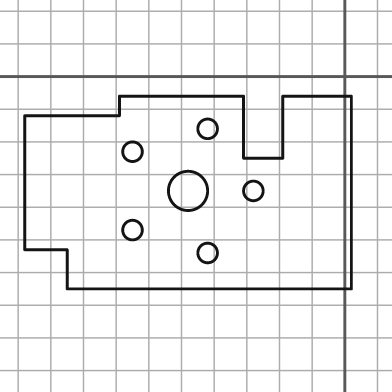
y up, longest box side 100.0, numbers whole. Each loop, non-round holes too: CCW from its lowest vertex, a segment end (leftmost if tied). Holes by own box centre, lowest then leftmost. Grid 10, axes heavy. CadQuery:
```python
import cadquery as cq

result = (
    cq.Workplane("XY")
    .moveTo(-85.0, -65.0)
    .lineTo(2.0, -65.0)
    .lineTo(2.0, -6.0)
    .lineTo(-19.0, -6.0)
    .lineTo(-19.0, -25.0)
    .lineTo(-31.0, -25.0)
    .lineTo(-31.0, -6.0)
    .lineTo(-69.0, -6.0)
    .lineTo(-69.0, -12.0)
    .lineTo(-98.0, -12.0)
    .lineTo(-98.0, -53.0)
    .lineTo(-85.0, -53.0)
    .close()
    .moveTo(-42.0, -54.0)
    .circle(3.0)
    .moveTo(-65.0, -47.0)
    .circle(3.0)
    .moveTo(-48.0, -35.0)
    .circle(6.0)
    .moveTo(-28.0, -35.0)
    .circle(3.0)
    .moveTo(-65.0, -23.0)
    .circle(3.0)
    .moveTo(-42.0, -16.0)
    .circle(3.0)
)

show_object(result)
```